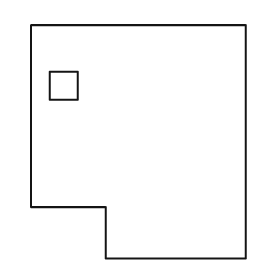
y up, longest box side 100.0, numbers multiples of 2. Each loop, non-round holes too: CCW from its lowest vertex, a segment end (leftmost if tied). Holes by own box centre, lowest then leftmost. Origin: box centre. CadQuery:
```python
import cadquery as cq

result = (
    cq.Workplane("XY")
    .moveTo(-14.0, -50.0)
    .lineTo(46.0, -50.0)
    .lineTo(46.0, 50.0)
    .lineTo(-46.0, 50.0)
    .lineTo(-46.0, -28.0)
    .lineTo(-14.0, -28.0)
    .close()
    .moveTo(-38.0, 18.0)
    .lineTo(-26.0, 18.0)
    .lineTo(-26.0, 30.0)
    .lineTo(-38.0, 30.0)
    .close()
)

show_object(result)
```